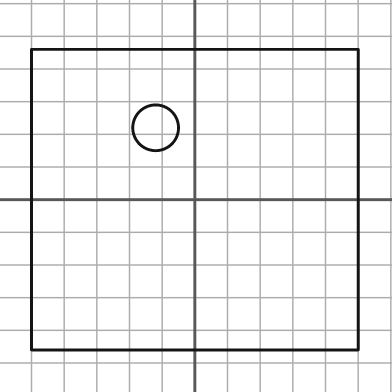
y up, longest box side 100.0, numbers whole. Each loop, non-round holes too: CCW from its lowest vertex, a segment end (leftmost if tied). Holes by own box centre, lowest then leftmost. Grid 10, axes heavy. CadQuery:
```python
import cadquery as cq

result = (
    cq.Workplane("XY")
    .moveTo(-50.0, -46.0)
    .lineTo(50.0, -46.0)
    .lineTo(50.0, 46.0)
    .lineTo(-50.0, 46.0)
    .close()
    .moveTo(-12.0, 22.0)
    .circle(7.0)
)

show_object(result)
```